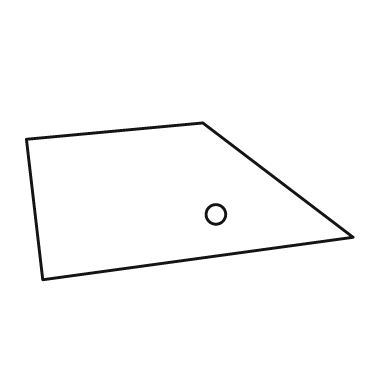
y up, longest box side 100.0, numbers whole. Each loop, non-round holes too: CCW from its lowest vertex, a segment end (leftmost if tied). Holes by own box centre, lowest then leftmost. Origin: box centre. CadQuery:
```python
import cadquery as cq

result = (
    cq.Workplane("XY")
    .moveTo(-45.0, -24.0)
    .lineTo(50.0, -11.0)
    .lineTo(4.0, 24.0)
    .lineTo(-50.0, 19.0)
    .close()
    .moveTo(8.0, -4.0)
    .circle(3.0)
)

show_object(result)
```